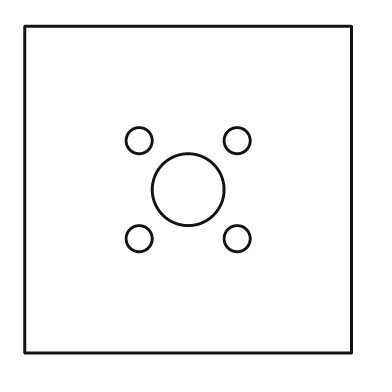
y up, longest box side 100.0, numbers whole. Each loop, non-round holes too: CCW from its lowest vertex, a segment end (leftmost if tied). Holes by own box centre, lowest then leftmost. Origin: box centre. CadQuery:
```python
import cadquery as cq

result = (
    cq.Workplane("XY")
    .moveTo(-50.0, -50.0)
    .lineTo(50.0, -50.0)
    .lineTo(50.0, 50.0)
    .lineTo(-50.0, 50.0)
    .close()
    .moveTo(-15.0, -15.0)
    .circle(4.0)
    .moveTo(15.0, -15.0)
    .circle(4.0)
    .moveTo(0.0, 0.0)
    .circle(11.0)
    .moveTo(-15.0, 15.0)
    .circle(4.0)
    .moveTo(15.0, 15.0)
    .circle(4.0)
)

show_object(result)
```